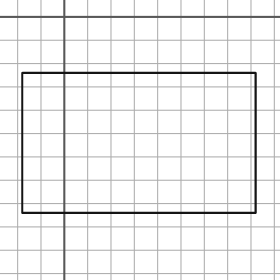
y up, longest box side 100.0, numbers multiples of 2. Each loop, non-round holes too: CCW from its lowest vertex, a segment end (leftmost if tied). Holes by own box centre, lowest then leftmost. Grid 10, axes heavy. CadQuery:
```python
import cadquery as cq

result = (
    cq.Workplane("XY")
    .moveTo(-18.0, -84.0)
    .lineTo(82.0, -84.0)
    .lineTo(82.0, -24.0)
    .lineTo(-18.0, -24.0)
    .close()
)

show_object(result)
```